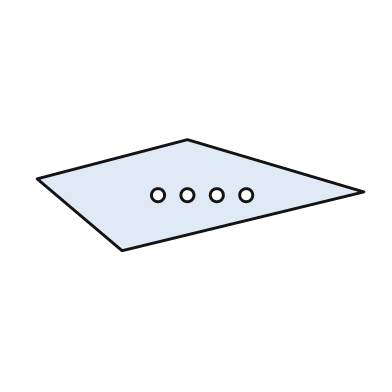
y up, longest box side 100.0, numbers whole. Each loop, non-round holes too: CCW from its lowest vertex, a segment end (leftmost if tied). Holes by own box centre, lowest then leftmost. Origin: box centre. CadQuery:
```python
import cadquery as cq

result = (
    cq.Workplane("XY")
    .moveTo(-24.0, -17.0)
    .lineTo(50.0, 1.0)
    .lineTo(-4.0, 17.0)
    .lineTo(-50.0, 5.0)
    .close()
    .moveTo(-13.0, 0.0)
    .circle(2.0)
    .moveTo(-4.0, 0.0)
    .circle(2.0)
    .moveTo(5.0, 0.0)
    .circle(2.0)
    .moveTo(14.0, 0.0)
    .circle(2.0)
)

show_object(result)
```